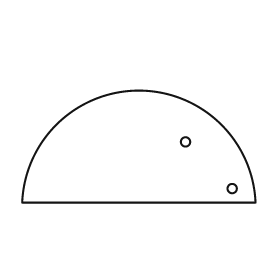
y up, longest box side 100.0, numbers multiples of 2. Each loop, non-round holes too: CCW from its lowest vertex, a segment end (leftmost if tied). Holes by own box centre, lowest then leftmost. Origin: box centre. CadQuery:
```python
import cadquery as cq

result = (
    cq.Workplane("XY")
    .moveTo(-50.0, -24.0)
    .lineTo(50.0, -24.0)
    .threePointArc((0.0, 24.0), (-50.0, -24.0))
    .close()
    .moveTo(40.0, -18.0)
    .circle(2.0)
    .moveTo(20.0, 2.0)
    .circle(2.0)
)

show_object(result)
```